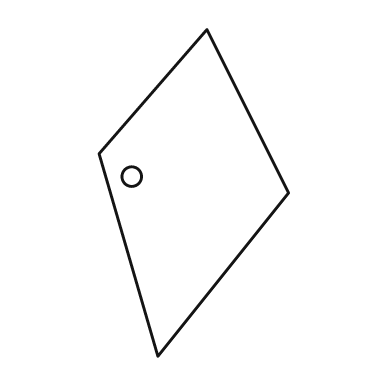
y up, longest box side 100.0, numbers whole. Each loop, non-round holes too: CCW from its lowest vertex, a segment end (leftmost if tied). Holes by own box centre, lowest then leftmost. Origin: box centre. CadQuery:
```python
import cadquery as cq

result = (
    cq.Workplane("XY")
    .moveTo(-11.0, -50.0)
    .lineTo(29.0, 0.0)
    .lineTo(4.0, 50.0)
    .lineTo(-29.0, 12.0)
    .close()
    .moveTo(-19.0, 5.0)
    .circle(3.0)
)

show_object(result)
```